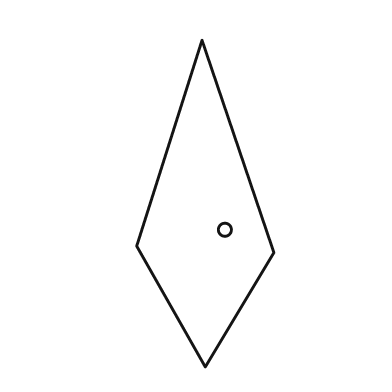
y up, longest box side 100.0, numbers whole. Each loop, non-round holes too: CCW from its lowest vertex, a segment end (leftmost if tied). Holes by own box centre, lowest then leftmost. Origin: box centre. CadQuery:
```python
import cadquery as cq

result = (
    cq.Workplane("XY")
    .moveTo(0.0, -50.0)
    .lineTo(21.0, -15.0)
    .lineTo(-1.0, 50.0)
    .lineTo(-21.0, -13.0)
    .close()
    .moveTo(6.0, -8.0)
    .circle(2.0)
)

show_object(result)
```